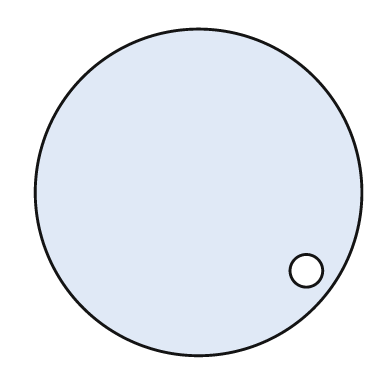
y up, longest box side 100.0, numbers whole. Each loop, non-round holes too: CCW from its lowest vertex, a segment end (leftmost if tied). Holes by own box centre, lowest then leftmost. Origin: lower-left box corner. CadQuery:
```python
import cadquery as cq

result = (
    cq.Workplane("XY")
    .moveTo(50.0, 50.0)
    .circle(50.0)
    .moveTo(83.0, 26.0)
    .circle(5.0)
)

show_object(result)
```